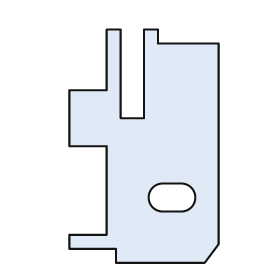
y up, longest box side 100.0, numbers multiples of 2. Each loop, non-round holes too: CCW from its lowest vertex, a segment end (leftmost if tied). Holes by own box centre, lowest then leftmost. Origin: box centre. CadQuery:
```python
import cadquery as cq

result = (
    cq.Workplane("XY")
    .moveTo(-12.0, -50.0)
    .lineTo(26.0, -50.0)
    .lineTo(32.0, -42.0)
    .lineTo(32.0, 44.0)
    .lineTo(6.0, 44.0)
    .lineTo(6.0, 50.0)
    .lineTo(0.0, 50.0)
    .lineTo(0.0, 12.0)
    .lineTo(-10.0, 12.0)
    .lineTo(-10.0, 50.0)
    .lineTo(-16.0, 50.0)
    .lineTo(-16.0, 24.0)
    .lineTo(-32.0, 24.0)
    .lineTo(-32.0, 0.0)
    .lineTo(-16.0, 0.0)
    .lineTo(-16.0, -38.0)
    .lineTo(-32.0, -38.0)
    .lineTo(-32.0, -44.0)
    .lineTo(-12.0, -44.0)
    .close()
    .moveTo(8.0, -28.0)
    .lineTo(16.0, -28.0)
    .threePointArc((22.0, -22.0), (16.0, -16.0))
    .lineTo(8.0, -16.0)
    .threePointArc((2.0, -22.0), (8.0, -28.0))
    .close()
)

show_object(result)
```